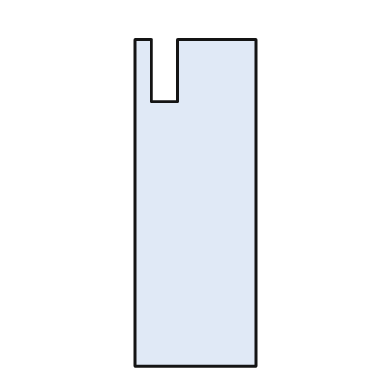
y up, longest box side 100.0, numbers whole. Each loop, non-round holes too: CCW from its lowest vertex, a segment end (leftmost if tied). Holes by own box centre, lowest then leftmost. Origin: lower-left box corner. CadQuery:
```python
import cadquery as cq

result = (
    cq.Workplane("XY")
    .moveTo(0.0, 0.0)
    .lineTo(37.0, 0.0)
    .lineTo(37.0, 100.0)
    .lineTo(13.0, 100.0)
    .lineTo(13.0, 81.0)
    .lineTo(5.0, 81.0)
    .lineTo(5.0, 100.0)
    .lineTo(0.0, 100.0)
    .close()
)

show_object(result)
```